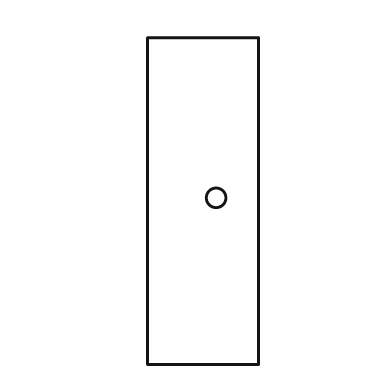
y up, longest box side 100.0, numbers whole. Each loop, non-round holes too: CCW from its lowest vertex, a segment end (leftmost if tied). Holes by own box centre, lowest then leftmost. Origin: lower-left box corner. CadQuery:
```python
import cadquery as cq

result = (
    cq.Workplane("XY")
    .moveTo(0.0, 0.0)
    .lineTo(34.0, 0.0)
    .lineTo(34.0, 100.0)
    .lineTo(0.0, 100.0)
    .close()
    .moveTo(21.0, 51.0)
    .circle(3.0)
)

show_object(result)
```